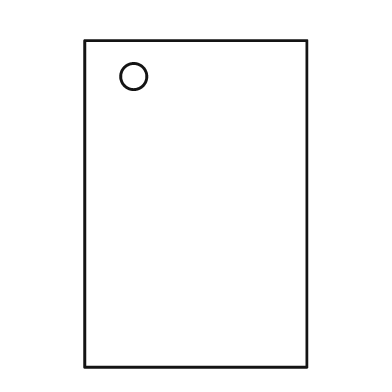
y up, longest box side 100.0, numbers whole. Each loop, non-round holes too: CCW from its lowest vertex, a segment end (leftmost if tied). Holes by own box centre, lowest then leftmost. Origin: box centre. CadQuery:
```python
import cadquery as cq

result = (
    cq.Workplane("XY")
    .moveTo(-34.0, -50.0)
    .lineTo(34.0, -50.0)
    .lineTo(34.0, 50.0)
    .lineTo(-34.0, 50.0)
    .close()
    .moveTo(-19.0, 39.0)
    .circle(4.0)
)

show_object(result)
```